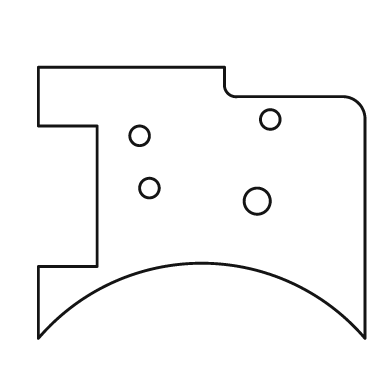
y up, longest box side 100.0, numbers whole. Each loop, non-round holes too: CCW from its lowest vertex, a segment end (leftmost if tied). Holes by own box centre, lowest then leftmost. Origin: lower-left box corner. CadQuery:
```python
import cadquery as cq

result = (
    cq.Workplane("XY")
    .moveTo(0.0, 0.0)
    .threePointArc((50.0, 23.0), (100.0, 0.0))
    .lineTo(100.0, 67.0)
    .threePointArc((98.0, 72.0), (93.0, 74.0))
    .lineTo(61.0, 74.0)
    .threePointArc((58.0, 75.0), (57.0, 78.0))
    .lineTo(57.0, 83.0)
    .lineTo(0.0, 83.0)
    .lineTo(0.0, 65.0)
    .lineTo(18.0, 65.0)
    .lineTo(18.0, 22.0)
    .lineTo(0.0, 22.0)
    .close()
    .moveTo(67.0, 42.0)
    .circle(4.0)
    .moveTo(34.0, 46.0)
    .circle(3.0)
    .moveTo(31.0, 62.0)
    .circle(3.0)
    .moveTo(71.0, 67.0)
    .circle(3.0)
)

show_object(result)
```